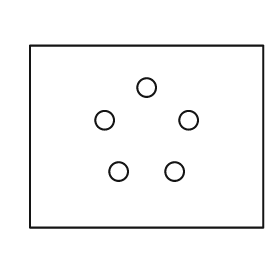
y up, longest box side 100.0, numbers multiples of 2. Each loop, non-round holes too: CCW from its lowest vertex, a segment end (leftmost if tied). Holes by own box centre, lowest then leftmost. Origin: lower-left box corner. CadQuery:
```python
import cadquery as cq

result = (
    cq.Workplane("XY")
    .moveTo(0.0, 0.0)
    .lineTo(100.0, 0.0)
    .lineTo(100.0, 78.0)
    .lineTo(0.0, 78.0)
    .close()
    .moveTo(38.0, 24.0)
    .circle(4.0)
    .moveTo(62.0, 24.0)
    .circle(4.0)
    .moveTo(32.0, 46.0)
    .circle(4.0)
    .moveTo(68.0, 46.0)
    .circle(4.0)
    .moveTo(50.0, 60.0)
    .circle(4.0)
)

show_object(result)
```